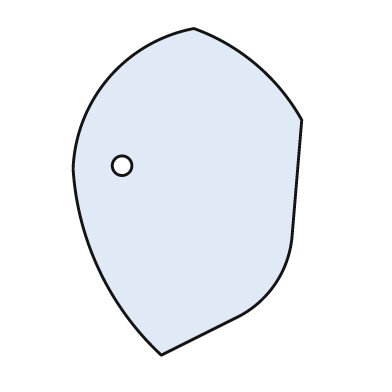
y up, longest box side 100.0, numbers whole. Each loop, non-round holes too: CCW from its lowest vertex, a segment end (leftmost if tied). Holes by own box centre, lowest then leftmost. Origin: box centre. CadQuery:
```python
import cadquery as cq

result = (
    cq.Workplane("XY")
    .moveTo(-8.0, -50.0)
    .lineTo(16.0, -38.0)
    .threePointArc((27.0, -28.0), (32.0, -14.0))
    .lineTo(35.0, 22.0)
    .threePointArc((21.0, 39.0), (2.0, 50.0))
    .threePointArc((-24.0, 35.0), (-35.0, 7.0))
    .threePointArc((-27.0, -24.0), (-8.0, -50.0))
    .close()
    .moveTo(-20.0, 8.0)
    .circle(3.0)
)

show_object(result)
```